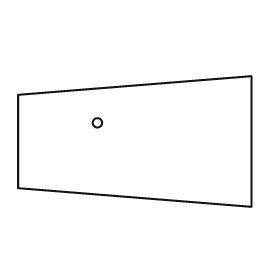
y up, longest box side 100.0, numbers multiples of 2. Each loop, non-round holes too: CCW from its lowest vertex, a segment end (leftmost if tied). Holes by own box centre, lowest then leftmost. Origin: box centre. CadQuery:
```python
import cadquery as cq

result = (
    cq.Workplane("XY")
    .moveTo(50.0, -28.0)
    .lineTo(50.0, 28.0)
    .lineTo(-50.0, 20.0)
    .lineTo(-50.0, -20.0)
    .close()
    .moveTo(-16.0, 8.0)
    .circle(2.0)
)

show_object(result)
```